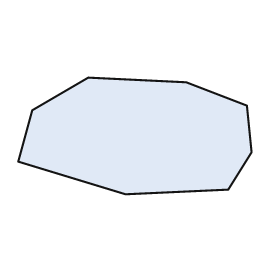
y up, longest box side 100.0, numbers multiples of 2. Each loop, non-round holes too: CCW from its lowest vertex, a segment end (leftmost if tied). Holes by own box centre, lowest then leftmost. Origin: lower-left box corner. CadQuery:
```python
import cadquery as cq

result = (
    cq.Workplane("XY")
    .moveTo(46.0, 0.0)
    .lineTo(90.0, 2.0)
    .lineTo(100.0, 18.0)
    .lineTo(98.0, 38.0)
    .lineTo(72.0, 48.0)
    .lineTo(30.0, 50.0)
    .lineTo(6.0, 36.0)
    .lineTo(0.0, 14.0)
    .close()
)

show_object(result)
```